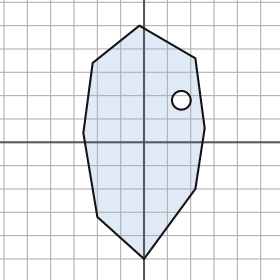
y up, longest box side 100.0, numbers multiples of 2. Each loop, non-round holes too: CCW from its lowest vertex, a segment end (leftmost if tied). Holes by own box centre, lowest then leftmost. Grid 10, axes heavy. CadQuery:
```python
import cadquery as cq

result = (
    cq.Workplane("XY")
    .moveTo(0.0, -50.0)
    .lineTo(22.0, -20.0)
    .lineTo(26.0, 6.0)
    .lineTo(22.0, 36.0)
    .lineTo(-2.0, 50.0)
    .lineTo(-22.0, 34.0)
    .lineTo(-26.0, 4.0)
    .lineTo(-20.0, -32.0)
    .close()
    .moveTo(16.0, 18.0)
    .circle(4.0)
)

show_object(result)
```